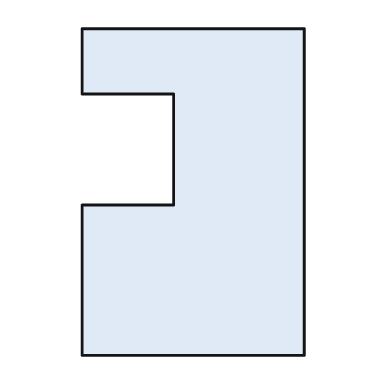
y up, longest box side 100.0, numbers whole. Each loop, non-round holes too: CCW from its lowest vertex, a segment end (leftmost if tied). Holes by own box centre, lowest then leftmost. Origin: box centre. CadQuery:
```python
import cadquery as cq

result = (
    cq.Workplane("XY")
    .moveTo(-34.0, -50.0)
    .lineTo(34.0, -50.0)
    .lineTo(34.0, 50.0)
    .lineTo(-34.0, 50.0)
    .lineTo(-34.0, 30.0)
    .lineTo(-6.0, 30.0)
    .lineTo(-6.0, -4.0)
    .lineTo(-34.0, -4.0)
    .close()
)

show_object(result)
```